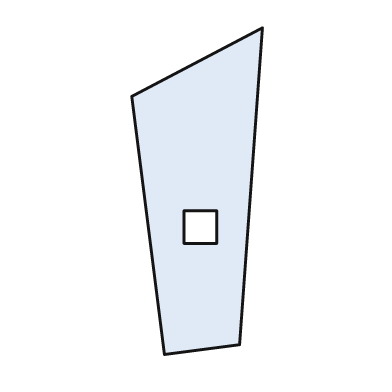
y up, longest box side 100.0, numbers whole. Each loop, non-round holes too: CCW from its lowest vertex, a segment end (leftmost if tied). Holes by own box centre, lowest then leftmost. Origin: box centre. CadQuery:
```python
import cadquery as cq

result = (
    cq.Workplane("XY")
    .moveTo(-10.0, -50.0)
    .lineTo(13.0, -47.0)
    .lineTo(20.0, 50.0)
    .lineTo(-20.0, 29.0)
    .close()
    .moveTo(-4.0, -16.0)
    .lineTo(6.0, -16.0)
    .lineTo(6.0, -6.0)
    .lineTo(-4.0, -6.0)
    .close()
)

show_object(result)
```